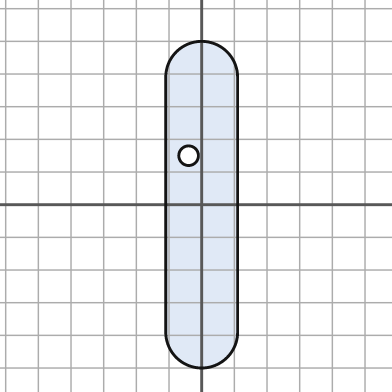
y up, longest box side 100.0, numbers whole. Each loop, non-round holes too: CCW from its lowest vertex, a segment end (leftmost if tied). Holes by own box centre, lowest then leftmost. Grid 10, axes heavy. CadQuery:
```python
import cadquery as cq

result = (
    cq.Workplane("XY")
    .moveTo(-11.0, -39.0)
    .threePointArc((0.0, -50.0), (11.0, -39.0))
    .lineTo(11.0, 39.0)
    .threePointArc((0.0, 50.0), (-11.0, 39.0))
    .close()
    .moveTo(-4.0, 15.0)
    .circle(3.0)
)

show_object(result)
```